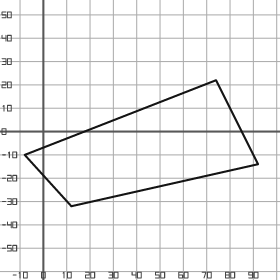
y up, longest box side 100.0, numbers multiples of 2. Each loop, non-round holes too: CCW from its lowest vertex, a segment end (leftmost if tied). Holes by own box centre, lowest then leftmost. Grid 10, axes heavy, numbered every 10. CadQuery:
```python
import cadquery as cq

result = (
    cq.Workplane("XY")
    .moveTo(12.0, -32.0)
    .lineTo(92.0, -14.0)
    .lineTo(74.0, 22.0)
    .lineTo(-8.0, -10.0)
    .close()
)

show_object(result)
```